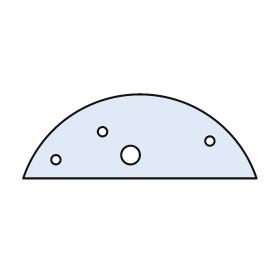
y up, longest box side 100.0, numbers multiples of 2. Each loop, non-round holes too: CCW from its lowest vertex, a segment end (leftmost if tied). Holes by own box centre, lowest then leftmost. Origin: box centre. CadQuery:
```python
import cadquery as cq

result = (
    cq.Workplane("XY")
    .moveTo(-50.0, -18.0)
    .lineTo(50.0, -18.0)
    .threePointArc((0.0, 18.0), (-50.0, -18.0))
    .close()
    .moveTo(-36.0, -10.0)
    .circle(2.0)
    .moveTo(-4.0, -8.0)
    .circle(4.0)
    .moveTo(30.0, -2.0)
    .circle(2.0)
    .moveTo(-16.0, 2.0)
    .circle(2.0)
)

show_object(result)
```